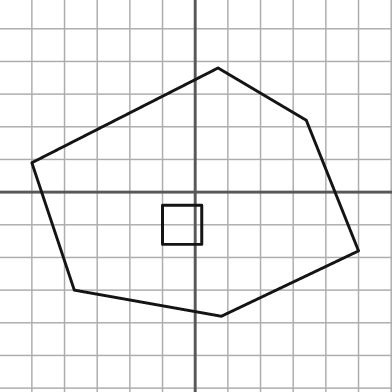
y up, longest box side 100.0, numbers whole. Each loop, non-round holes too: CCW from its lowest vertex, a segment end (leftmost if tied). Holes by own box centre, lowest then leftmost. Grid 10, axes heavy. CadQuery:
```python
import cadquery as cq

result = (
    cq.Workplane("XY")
    .moveTo(8.0, -38.0)
    .lineTo(50.0, -18.0)
    .lineTo(34.0, 22.0)
    .lineTo(7.0, 38.0)
    .lineTo(-50.0, 9.0)
    .lineTo(-37.0, -30.0)
    .close()
    .moveTo(-10.0, -16.0)
    .lineTo(2.0, -16.0)
    .lineTo(2.0, -4.0)
    .lineTo(-10.0, -4.0)
    .close()
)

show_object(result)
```